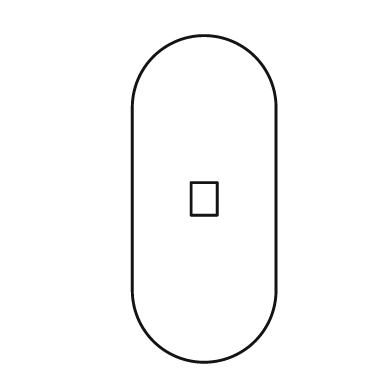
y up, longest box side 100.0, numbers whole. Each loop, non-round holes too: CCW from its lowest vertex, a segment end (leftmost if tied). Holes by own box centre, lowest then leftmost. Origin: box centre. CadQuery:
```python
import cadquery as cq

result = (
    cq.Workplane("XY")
    .moveTo(-22.0, -28.0)
    .threePointArc((0.0, -50.0), (22.0, -28.0))
    .lineTo(22.0, 28.0)
    .threePointArc((0.0, 50.0), (-22.0, 28.0))
    .close()
    .moveTo(-4.0, -5.0)
    .lineTo(4.0, -5.0)
    .lineTo(4.0, 5.0)
    .lineTo(-4.0, 5.0)
    .close()
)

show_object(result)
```